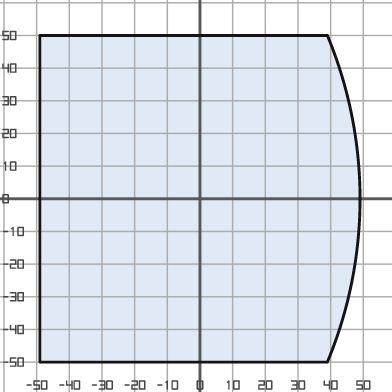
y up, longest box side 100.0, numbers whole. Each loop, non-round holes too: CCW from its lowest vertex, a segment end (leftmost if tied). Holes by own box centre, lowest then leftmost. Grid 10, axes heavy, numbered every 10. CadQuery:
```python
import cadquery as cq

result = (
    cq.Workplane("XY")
    .moveTo(-49.0, -50.0)
    .lineTo(39.0, -50.0)
    .threePointArc((49.0, 0.0), (39.0, 50.0))
    .lineTo(-49.0, 50.0)
    .close()
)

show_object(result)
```